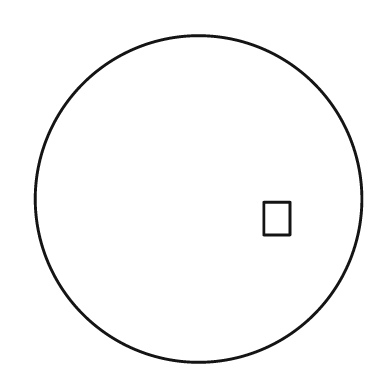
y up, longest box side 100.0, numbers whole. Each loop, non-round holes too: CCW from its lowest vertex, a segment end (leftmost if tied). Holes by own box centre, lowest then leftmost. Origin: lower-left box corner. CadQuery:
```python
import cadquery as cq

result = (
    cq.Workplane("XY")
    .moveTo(50.0, 50.0)
    .circle(50.0)
    .moveTo(70.0, 39.0)
    .lineTo(78.0, 39.0)
    .lineTo(78.0, 49.0)
    .lineTo(70.0, 49.0)
    .close()
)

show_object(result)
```